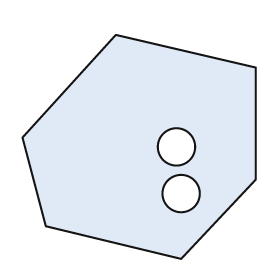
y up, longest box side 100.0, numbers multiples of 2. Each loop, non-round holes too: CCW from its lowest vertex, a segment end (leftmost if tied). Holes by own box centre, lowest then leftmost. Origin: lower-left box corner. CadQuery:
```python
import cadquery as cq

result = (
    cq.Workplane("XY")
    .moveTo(68.0, 0.0)
    .lineTo(100.0, 34.0)
    .lineTo(100.0, 82.0)
    .lineTo(40.0, 96.0)
    .lineTo(0.0, 52.0)
    .lineTo(10.0, 14.0)
    .close()
    .moveTo(68.0, 28.0)
    .circle(8.0)
    .moveTo(66.0, 48.0)
    .circle(8.0)
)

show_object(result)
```